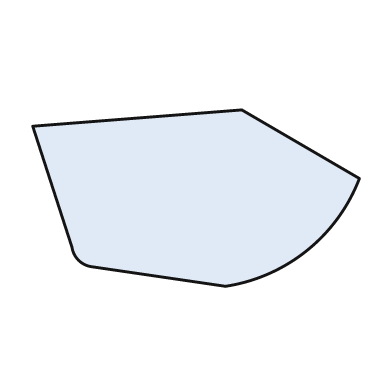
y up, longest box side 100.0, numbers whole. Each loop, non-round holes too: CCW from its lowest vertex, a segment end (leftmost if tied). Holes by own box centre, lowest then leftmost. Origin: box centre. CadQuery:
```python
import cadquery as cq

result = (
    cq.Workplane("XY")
    .moveTo(9.0, -27.0)
    .threePointArc((34.0, -16.0), (50.0, 6.0))
    .lineTo(14.0, 27.0)
    .lineTo(-50.0, 22.0)
    .lineTo(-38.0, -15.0)
    .threePointArc((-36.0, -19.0), (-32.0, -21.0))
    .close()
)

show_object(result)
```